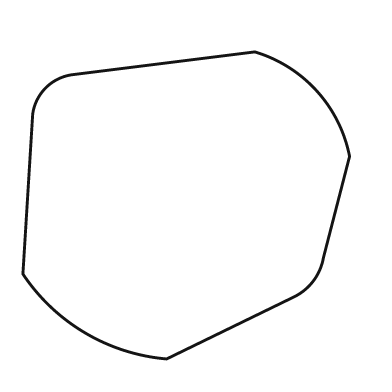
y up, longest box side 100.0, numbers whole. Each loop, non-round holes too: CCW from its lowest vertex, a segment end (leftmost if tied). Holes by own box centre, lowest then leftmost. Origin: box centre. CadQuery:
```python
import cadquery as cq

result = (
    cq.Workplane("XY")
    .moveTo(-6.0, -47.0)
    .lineTo(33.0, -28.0)
    .threePointArc((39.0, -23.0), (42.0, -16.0))
    .lineTo(50.0, 15.0)
    .threePointArc((40.0, 35.0), (21.0, 47.0))
    .lineTo(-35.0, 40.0)
    .threePointArc((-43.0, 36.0), (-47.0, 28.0))
    .lineTo(-50.0, -21.0)
    .threePointArc((-31.0, -39.0), (-6.0, -47.0))
    .close()
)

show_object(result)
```